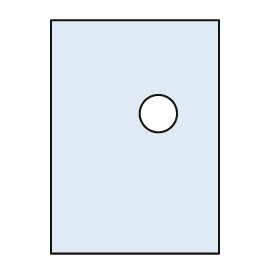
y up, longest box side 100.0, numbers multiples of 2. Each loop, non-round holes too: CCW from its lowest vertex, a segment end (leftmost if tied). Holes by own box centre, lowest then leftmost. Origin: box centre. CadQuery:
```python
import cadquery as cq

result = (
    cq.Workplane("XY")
    .moveTo(-36.0, -50.0)
    .lineTo(36.0, -50.0)
    .lineTo(36.0, 50.0)
    .lineTo(-36.0, 50.0)
    .close()
    .moveTo(10.0, 10.0)
    .circle(8.0)
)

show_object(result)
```